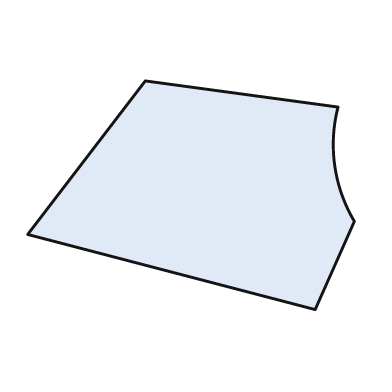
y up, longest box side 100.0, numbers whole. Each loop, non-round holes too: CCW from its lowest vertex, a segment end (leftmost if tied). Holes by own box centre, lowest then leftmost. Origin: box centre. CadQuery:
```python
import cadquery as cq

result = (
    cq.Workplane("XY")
    .moveTo(38.0, -35.0)
    .lineTo(50.0, -8.0)
    .threePointArc((44.0, 9.0), (45.0, 27.0))
    .lineTo(-14.0, 35.0)
    .lineTo(-50.0, -12.0)
    .close()
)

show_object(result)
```